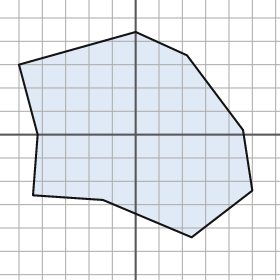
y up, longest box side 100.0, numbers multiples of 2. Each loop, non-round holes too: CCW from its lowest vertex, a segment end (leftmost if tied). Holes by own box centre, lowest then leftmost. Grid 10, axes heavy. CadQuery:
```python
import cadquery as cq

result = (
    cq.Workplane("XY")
    .moveTo(24.0, -44.0)
    .lineTo(50.0, -24.0)
    .lineTo(46.0, 2.0)
    .lineTo(22.0, 34.0)
    .lineTo(0.0, 44.0)
    .lineTo(-50.0, 30.0)
    .lineTo(-42.0, 0.0)
    .lineTo(-44.0, -26.0)
    .lineTo(-14.0, -28.0)
    .close()
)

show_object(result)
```